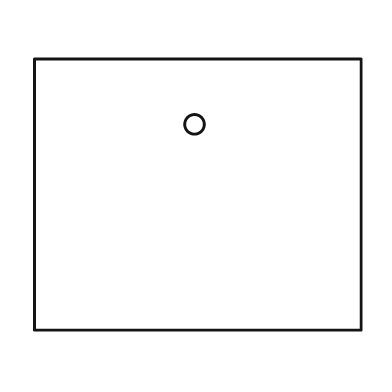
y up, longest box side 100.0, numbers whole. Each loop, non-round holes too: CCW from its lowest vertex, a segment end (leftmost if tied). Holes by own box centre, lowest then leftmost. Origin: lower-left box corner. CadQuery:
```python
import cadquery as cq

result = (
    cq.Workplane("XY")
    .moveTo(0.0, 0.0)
    .lineTo(100.0, 0.0)
    .lineTo(100.0, 83.0)
    .lineTo(0.0, 83.0)
    .close()
    .moveTo(49.0, 63.0)
    .circle(3.0)
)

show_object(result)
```